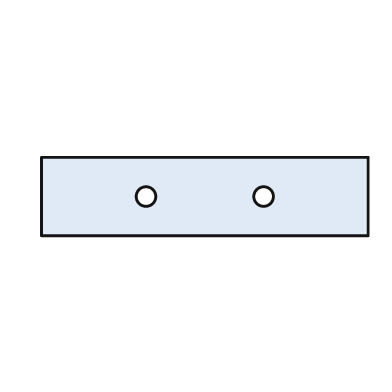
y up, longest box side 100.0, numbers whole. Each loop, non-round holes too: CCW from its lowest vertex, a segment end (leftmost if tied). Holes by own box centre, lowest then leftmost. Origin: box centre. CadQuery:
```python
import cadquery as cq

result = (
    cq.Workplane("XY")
    .moveTo(-50.0, -12.0)
    .lineTo(50.0, -12.0)
    .lineTo(50.0, 12.0)
    .lineTo(-50.0, 12.0)
    .close()
    .moveTo(-18.0, 0.0)
    .circle(3.0)
    .moveTo(18.0, 0.0)
    .circle(3.0)
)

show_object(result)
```